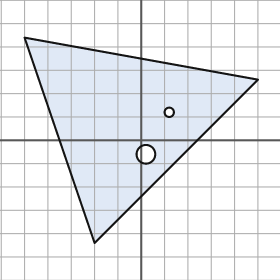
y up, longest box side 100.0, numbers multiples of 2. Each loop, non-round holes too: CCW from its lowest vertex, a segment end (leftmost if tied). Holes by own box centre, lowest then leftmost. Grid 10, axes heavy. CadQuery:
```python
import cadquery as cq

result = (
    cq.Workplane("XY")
    .moveTo(-20.0, -44.0)
    .lineTo(50.0, 26.0)
    .lineTo(-50.0, 44.0)
    .close()
    .moveTo(2.0, -6.0)
    .circle(4.0)
    .moveTo(12.0, 12.0)
    .circle(2.0)
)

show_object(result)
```